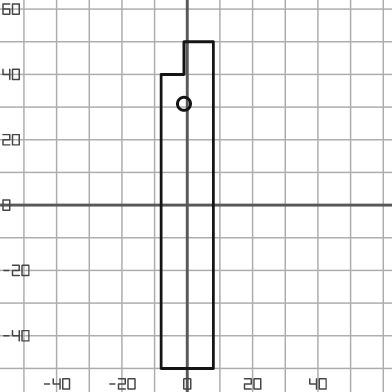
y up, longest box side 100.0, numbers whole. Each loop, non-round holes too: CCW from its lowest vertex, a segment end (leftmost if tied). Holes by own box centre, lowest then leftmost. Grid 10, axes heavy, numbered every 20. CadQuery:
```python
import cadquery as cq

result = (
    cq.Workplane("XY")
    .moveTo(-8.0, -50.0)
    .lineTo(8.0, -50.0)
    .lineTo(8.0, 50.0)
    .lineTo(-1.0, 50.0)
    .lineTo(-1.0, 40.0)
    .lineTo(-8.0, 40.0)
    .close()
    .moveTo(-1.0, 31.0)
    .circle(2.0)
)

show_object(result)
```